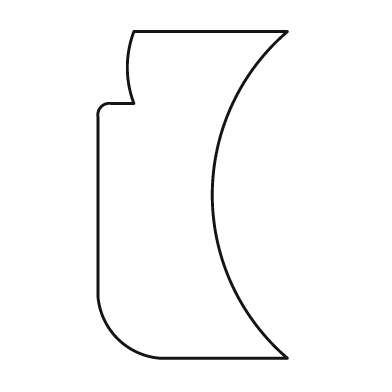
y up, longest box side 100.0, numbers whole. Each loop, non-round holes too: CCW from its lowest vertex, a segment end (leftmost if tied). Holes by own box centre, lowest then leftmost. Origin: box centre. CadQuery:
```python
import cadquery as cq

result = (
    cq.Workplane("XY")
    .moveTo(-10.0, -50.0)
    .lineTo(29.0, -50.0)
    .threePointArc((6.0, 0.0), (29.0, 50.0))
    .lineTo(-18.0, 50.0)
    .threePointArc((-20.0, 39.0), (-18.0, 28.0))
    .lineTo(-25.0, 28.0)
    .threePointArc((-28.0, 27.0), (-29.0, 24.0))
    .lineTo(-29.0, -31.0)
    .threePointArc((-23.0, -44.0), (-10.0, -50.0))
    .close()
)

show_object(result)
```